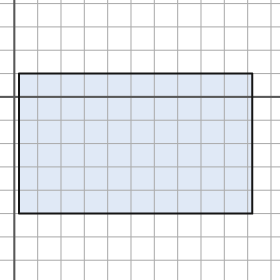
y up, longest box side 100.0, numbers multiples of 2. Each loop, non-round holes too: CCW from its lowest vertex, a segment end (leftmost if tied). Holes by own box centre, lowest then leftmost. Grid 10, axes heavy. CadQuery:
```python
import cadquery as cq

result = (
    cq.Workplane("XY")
    .moveTo(2.0, -50.0)
    .lineTo(102.0, -50.0)
    .lineTo(102.0, 10.0)
    .lineTo(2.0, 10.0)
    .close()
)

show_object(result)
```